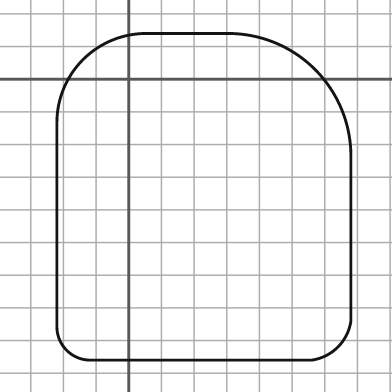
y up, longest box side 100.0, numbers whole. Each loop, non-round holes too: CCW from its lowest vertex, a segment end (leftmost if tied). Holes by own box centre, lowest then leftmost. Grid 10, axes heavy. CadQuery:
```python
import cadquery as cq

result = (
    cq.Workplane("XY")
    .moveTo(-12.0, -86.0)
    .lineTo(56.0, -86.0)
    .threePointArc((64.0, -82.0), (68.0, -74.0))
    .lineTo(68.0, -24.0)
    .threePointArc((57.0, 3.0), (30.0, 14.0))
    .lineTo(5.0, 14.0)
    .threePointArc((-14.0, 6.0), (-22.0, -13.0))
    .lineTo(-22.0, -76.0)
    .threePointArc((-19.0, -83.0), (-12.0, -86.0))
    .close()
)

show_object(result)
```